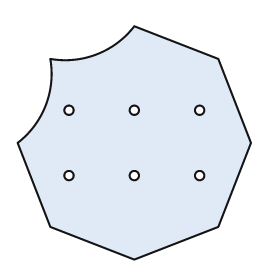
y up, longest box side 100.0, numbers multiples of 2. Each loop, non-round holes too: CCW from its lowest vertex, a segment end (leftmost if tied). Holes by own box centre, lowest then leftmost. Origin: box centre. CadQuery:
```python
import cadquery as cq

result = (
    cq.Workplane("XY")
    .moveTo(0.0, -50.0)
    .lineTo(36.0, -36.0)
    .lineTo(50.0, 0.0)
    .lineTo(36.0, 36.0)
    .lineTo(0.0, 50.0)
    .threePointArc((-16.0, 38.0), (-36.0, 36.0))
    .threePointArc((-38.0, 16.0), (-50.0, 0.0))
    .lineTo(-36.0, -36.0)
    .close()
    .moveTo(-28.0, -14.0)
    .circle(2.0)
    .moveTo(0.0, -14.0)
    .circle(2.0)
    .moveTo(28.0, -14.0)
    .circle(2.0)
    .moveTo(-28.0, 14.0)
    .circle(2.0)
    .moveTo(0.0, 14.0)
    .circle(2.0)
    .moveTo(28.0, 14.0)
    .circle(2.0)
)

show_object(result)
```